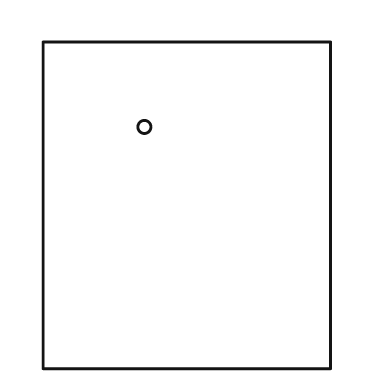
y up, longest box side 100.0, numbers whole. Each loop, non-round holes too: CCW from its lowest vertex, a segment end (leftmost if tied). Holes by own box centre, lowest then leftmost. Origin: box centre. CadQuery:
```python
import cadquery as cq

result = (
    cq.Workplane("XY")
    .moveTo(-44.0, -50.0)
    .lineTo(44.0, -50.0)
    .lineTo(44.0, 50.0)
    .lineTo(-44.0, 50.0)
    .close()
    .moveTo(-13.0, 24.0)
    .circle(2.0)
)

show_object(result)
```